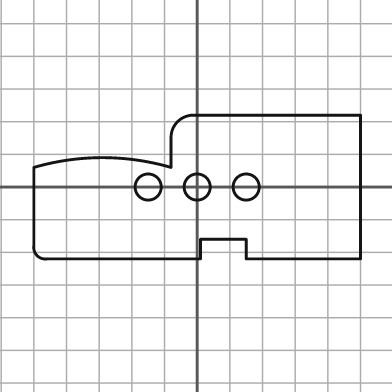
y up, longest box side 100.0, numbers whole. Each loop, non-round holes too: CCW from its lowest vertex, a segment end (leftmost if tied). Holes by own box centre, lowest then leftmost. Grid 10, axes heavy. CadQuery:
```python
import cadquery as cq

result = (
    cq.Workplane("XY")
    .moveTo(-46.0, -22.0)
    .lineTo(1.0, -22.0)
    .lineTo(1.0, -16.0)
    .lineTo(15.0, -16.0)
    .lineTo(15.0, -22.0)
    .lineTo(50.0, -22.0)
    .lineTo(50.0, 22.0)
    .lineTo(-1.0, 22.0)
    .threePointArc((-6.0, 20.0), (-8.0, 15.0))
    .lineTo(-8.0, 6.0)
    .threePointArc((-29.0, 9.0), (-50.0, 6.0))
    .lineTo(-50.0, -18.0)
    .threePointArc((-49.0, -21.0), (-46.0, -22.0))
    .close()
    .moveTo(-15.0, 0.0)
    .circle(4.0)
    .moveTo(0.0, 0.0)
    .circle(4.0)
    .moveTo(15.0, 0.0)
    .circle(4.0)
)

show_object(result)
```